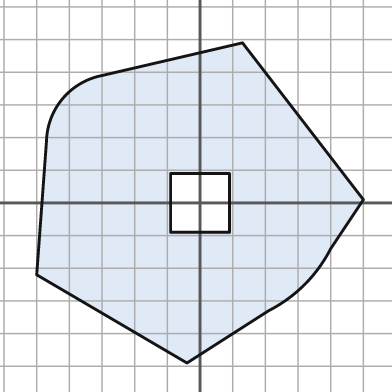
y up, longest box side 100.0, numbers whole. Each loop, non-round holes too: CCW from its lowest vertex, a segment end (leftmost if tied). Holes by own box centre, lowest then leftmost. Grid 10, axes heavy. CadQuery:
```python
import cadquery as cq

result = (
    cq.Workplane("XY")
    .moveTo(-4.0, -49.0)
    .lineTo(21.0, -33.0)
    .threePointArc((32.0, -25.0), (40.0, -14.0))
    .lineTo(50.0, 1.0)
    .lineTo(13.0, 49.0)
    .lineTo(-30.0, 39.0)
    .threePointArc((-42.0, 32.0), (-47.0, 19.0))
    .lineTo(-50.0, -22.0)
    .close()
    .moveTo(-9.0, -9.0)
    .lineTo(9.0, -9.0)
    .lineTo(9.0, 9.0)
    .lineTo(-9.0, 9.0)
    .close()
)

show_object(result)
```